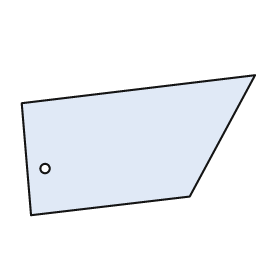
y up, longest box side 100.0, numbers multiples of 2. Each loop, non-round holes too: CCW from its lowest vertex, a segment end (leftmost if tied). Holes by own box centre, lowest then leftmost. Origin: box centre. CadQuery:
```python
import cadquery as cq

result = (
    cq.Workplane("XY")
    .moveTo(-46.0, -30.0)
    .lineTo(22.0, -22.0)
    .lineTo(50.0, 30.0)
    .lineTo(-50.0, 18.0)
    .close()
    .moveTo(-40.0, -10.0)
    .circle(2.0)
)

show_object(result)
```